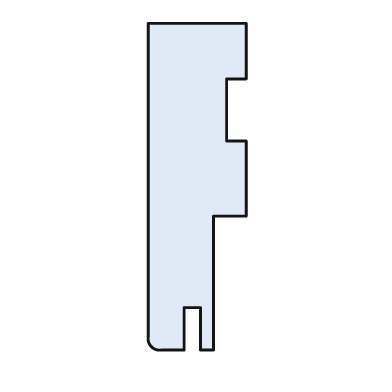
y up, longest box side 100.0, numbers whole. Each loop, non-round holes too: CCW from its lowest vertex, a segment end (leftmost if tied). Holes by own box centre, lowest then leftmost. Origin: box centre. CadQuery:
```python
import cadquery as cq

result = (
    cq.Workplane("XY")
    .moveTo(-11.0, -50.0)
    .lineTo(-4.0, -50.0)
    .lineTo(-4.0, -37.0)
    .lineTo(1.0, -37.0)
    .lineTo(1.0, -50.0)
    .lineTo(5.0, -50.0)
    .lineTo(5.0, -9.0)
    .lineTo(15.0, -9.0)
    .lineTo(15.0, 14.0)
    .lineTo(9.0, 14.0)
    .lineTo(9.0, 33.0)
    .lineTo(15.0, 33.0)
    .lineTo(15.0, 50.0)
    .lineTo(-15.0, 50.0)
    .lineTo(-15.0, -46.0)
    .threePointArc((-14.0, -49.0), (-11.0, -50.0))
    .close()
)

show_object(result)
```